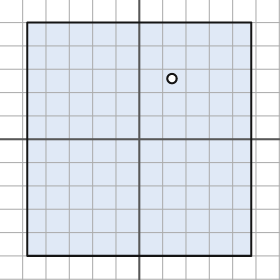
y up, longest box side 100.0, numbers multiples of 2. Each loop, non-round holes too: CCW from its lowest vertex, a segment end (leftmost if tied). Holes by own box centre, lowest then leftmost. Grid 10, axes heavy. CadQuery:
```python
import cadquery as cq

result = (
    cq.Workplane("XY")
    .moveTo(-48.0, -50.0)
    .lineTo(48.0, -50.0)
    .lineTo(48.0, 50.0)
    .lineTo(-48.0, 50.0)
    .close()
    .moveTo(14.0, 26.0)
    .circle(2.0)
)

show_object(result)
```